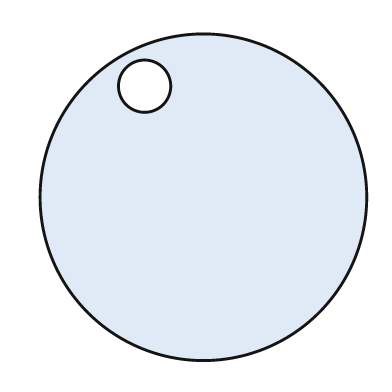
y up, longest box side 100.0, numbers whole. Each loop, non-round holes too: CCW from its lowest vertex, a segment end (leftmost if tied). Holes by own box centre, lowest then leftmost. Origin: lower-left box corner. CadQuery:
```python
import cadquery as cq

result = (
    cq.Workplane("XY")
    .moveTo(50.0, 50.0)
    .circle(50.0)
    .moveTo(32.0, 84.0)
    .circle(8.0)
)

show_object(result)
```